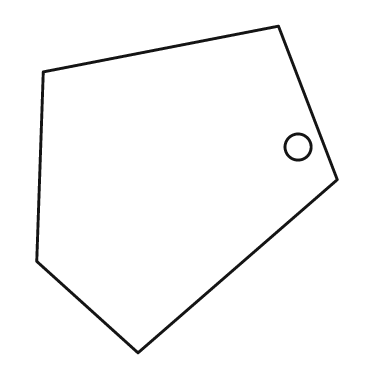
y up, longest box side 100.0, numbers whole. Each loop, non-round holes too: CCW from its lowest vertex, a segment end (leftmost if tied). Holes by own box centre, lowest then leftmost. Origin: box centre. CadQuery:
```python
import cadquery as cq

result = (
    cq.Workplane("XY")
    .moveTo(-15.0, -50.0)
    .lineTo(46.0, 3.0)
    .lineTo(28.0, 50.0)
    .lineTo(-44.0, 36.0)
    .lineTo(-46.0, -22.0)
    .close()
    .moveTo(34.0, 13.0)
    .circle(4.0)
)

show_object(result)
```